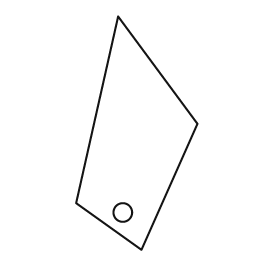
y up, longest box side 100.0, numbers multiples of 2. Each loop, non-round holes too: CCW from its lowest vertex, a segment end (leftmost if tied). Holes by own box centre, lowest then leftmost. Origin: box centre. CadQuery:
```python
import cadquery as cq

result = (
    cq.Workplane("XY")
    .moveTo(2.0, -50.0)
    .lineTo(26.0, 4.0)
    .lineTo(-8.0, 50.0)
    .lineTo(-26.0, -30.0)
    .close()
    .moveTo(-6.0, -34.0)
    .circle(4.0)
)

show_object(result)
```